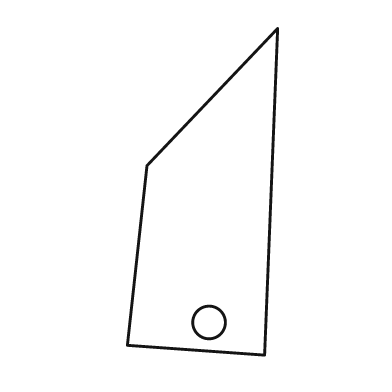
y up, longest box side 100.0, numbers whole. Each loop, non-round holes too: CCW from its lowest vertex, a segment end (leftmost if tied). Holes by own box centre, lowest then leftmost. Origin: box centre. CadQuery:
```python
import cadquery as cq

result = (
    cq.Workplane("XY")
    .moveTo(19.0, -50.0)
    .lineTo(23.0, 50.0)
    .lineTo(-17.0, 8.0)
    .lineTo(-23.0, -47.0)
    .close()
    .moveTo(2.0, -40.0)
    .circle(5.0)
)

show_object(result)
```